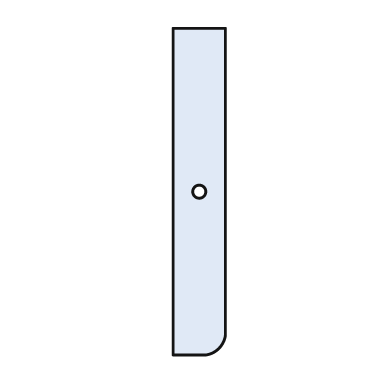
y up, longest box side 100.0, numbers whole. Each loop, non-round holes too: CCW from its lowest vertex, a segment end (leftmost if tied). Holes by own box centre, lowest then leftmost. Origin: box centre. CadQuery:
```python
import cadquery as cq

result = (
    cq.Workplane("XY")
    .moveTo(-8.0, -50.0)
    .lineTo(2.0, -50.0)
    .threePointArc((6.0, -48.0), (8.0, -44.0))
    .lineTo(8.0, 50.0)
    .lineTo(-8.0, 50.0)
    .close()
    .moveTo(0.0, 0.0)
    .circle(2.0)
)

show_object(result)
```